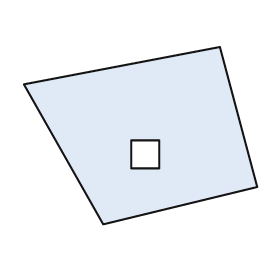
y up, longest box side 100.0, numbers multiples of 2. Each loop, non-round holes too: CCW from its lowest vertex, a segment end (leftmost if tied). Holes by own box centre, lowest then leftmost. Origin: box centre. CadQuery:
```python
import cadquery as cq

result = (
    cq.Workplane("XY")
    .moveTo(-16.0, -38.0)
    .lineTo(50.0, -22.0)
    .lineTo(34.0, 38.0)
    .lineTo(-50.0, 22.0)
    .close()
    .moveTo(-4.0, -14.0)
    .lineTo(8.0, -14.0)
    .lineTo(8.0, -2.0)
    .lineTo(-4.0, -2.0)
    .close()
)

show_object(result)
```